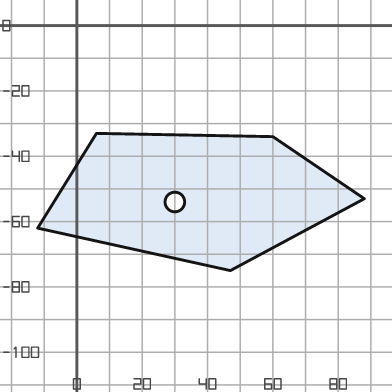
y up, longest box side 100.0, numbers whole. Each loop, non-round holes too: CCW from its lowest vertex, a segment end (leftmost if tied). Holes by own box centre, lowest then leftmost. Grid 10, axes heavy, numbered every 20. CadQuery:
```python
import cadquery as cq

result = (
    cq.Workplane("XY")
    .moveTo(47.0, -75.0)
    .lineTo(88.0, -53.0)
    .lineTo(60.0, -34.0)
    .lineTo(6.0, -33.0)
    .lineTo(-12.0, -62.0)
    .close()
    .moveTo(30.0, -54.0)
    .circle(3.0)
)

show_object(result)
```